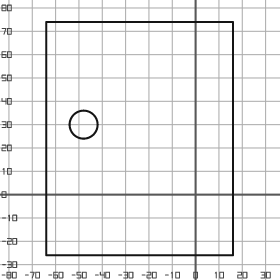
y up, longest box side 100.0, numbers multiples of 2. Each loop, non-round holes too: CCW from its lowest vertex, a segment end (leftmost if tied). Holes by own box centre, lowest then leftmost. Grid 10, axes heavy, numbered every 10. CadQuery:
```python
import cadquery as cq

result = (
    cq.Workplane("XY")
    .moveTo(-64.0, -26.0)
    .lineTo(16.0, -26.0)
    .lineTo(16.0, 74.0)
    .lineTo(-64.0, 74.0)
    .close()
    .moveTo(-48.0, 30.0)
    .circle(6.0)
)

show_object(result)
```